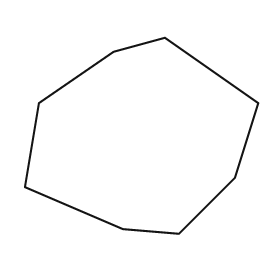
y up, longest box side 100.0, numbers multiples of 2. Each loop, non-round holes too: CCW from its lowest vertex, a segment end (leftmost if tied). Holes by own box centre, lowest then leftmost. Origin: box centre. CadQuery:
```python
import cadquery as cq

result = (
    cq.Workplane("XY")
    .moveTo(16.0, -42.0)
    .lineTo(40.0, -18.0)
    .lineTo(50.0, 14.0)
    .lineTo(10.0, 42.0)
    .lineTo(-12.0, 36.0)
    .lineTo(-44.0, 14.0)
    .lineTo(-50.0, -22.0)
    .lineTo(-8.0, -40.0)
    .close()
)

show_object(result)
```